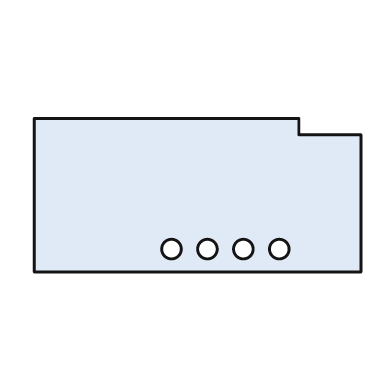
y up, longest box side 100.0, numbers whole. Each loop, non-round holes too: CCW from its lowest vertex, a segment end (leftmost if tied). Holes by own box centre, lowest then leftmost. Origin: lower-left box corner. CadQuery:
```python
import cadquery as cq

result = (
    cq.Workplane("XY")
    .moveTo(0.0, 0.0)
    .lineTo(100.0, 0.0)
    .lineTo(100.0, 42.0)
    .lineTo(81.0, 42.0)
    .lineTo(81.0, 47.0)
    .lineTo(0.0, 47.0)
    .close()
    .moveTo(42.0, 7.0)
    .circle(3.0)
    .moveTo(53.0, 7.0)
    .circle(3.0)
    .moveTo(64.0, 7.0)
    .circle(3.0)
    .moveTo(75.0, 7.0)
    .circle(3.0)
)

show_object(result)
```